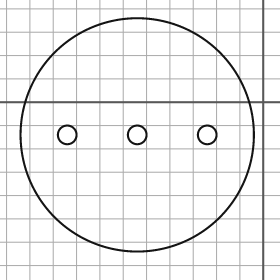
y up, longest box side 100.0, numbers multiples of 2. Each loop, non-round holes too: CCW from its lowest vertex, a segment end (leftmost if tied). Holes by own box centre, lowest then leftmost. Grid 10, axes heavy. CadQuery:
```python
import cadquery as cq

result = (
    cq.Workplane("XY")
    .moveTo(-54.0, -14.0)
    .circle(50.0)
    .moveTo(-84.0, -14.0)
    .circle(4.0)
    .moveTo(-54.0, -14.0)
    .circle(4.0)
    .moveTo(-24.0, -14.0)
    .circle(4.0)
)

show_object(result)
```